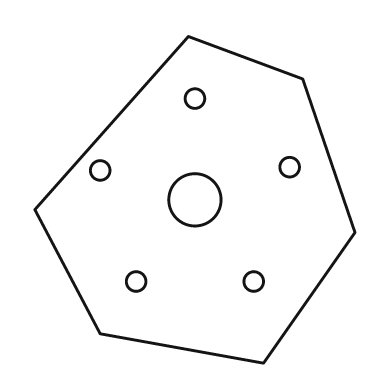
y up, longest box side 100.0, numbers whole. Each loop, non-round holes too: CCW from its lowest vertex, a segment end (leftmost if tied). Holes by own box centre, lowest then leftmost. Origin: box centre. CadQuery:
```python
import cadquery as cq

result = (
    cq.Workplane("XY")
    .moveTo(21.0, -50.0)
    .lineTo(49.0, -10.0)
    .lineTo(33.0, 37.0)
    .lineTo(-2.0, 50.0)
    .lineTo(-49.0, -3.0)
    .lineTo(-29.0, -41.0)
    .close()
    .moveTo(-18.0, -25.0)
    .circle(3.0)
    .moveTo(18.0, -25.0)
    .circle(3.0)
    .moveTo(0.0, 0.0)
    .circle(8.0)
    .moveTo(-29.0, 9.0)
    .circle(3.0)
    .moveTo(29.0, 10.0)
    .circle(3.0)
    .moveTo(0.0, 31.0)
    .circle(3.0)
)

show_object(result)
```